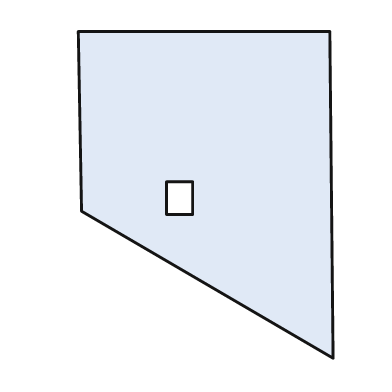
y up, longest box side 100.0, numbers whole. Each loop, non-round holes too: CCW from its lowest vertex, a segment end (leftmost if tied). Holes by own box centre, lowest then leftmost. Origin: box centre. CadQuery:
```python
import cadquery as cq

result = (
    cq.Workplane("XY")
    .moveTo(39.0, -50.0)
    .lineTo(38.0, 50.0)
    .lineTo(-39.0, 50.0)
    .lineTo(-38.0, -5.0)
    .close()
    .moveTo(-12.0, -6.0)
    .lineTo(-4.0, -6.0)
    .lineTo(-4.0, 4.0)
    .lineTo(-12.0, 4.0)
    .close()
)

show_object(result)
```